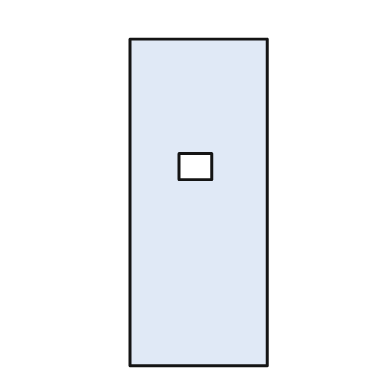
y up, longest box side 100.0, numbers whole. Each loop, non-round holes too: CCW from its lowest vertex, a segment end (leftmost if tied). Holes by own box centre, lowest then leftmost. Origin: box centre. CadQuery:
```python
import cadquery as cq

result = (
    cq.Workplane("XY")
    .moveTo(-21.0, -50.0)
    .lineTo(21.0, -50.0)
    .lineTo(21.0, 50.0)
    .lineTo(-21.0, 50.0)
    .close()
    .moveTo(-6.0, 7.0)
    .lineTo(4.0, 7.0)
    .lineTo(4.0, 15.0)
    .lineTo(-6.0, 15.0)
    .close()
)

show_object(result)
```